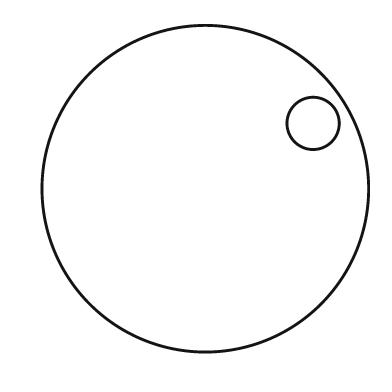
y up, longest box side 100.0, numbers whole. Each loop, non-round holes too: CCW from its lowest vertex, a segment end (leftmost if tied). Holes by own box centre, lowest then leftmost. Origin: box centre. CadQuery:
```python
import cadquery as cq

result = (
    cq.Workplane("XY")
    .moveTo(0.0, 0.0)
    .circle(50.0)
    .moveTo(33.0, 20.0)
    .circle(8.0)
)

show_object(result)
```